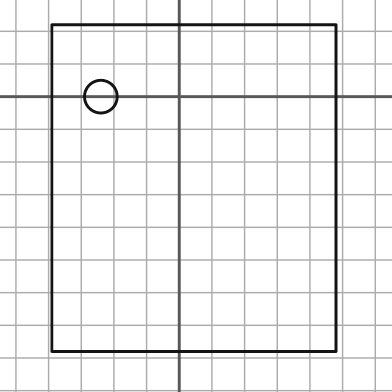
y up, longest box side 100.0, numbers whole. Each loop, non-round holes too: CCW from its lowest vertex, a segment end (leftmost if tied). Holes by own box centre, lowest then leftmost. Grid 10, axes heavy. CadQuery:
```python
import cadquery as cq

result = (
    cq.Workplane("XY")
    .moveTo(-39.0, -78.0)
    .lineTo(48.0, -78.0)
    .lineTo(48.0, 22.0)
    .lineTo(-39.0, 22.0)
    .close()
    .moveTo(-24.0, 0.0)
    .circle(5.0)
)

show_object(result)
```